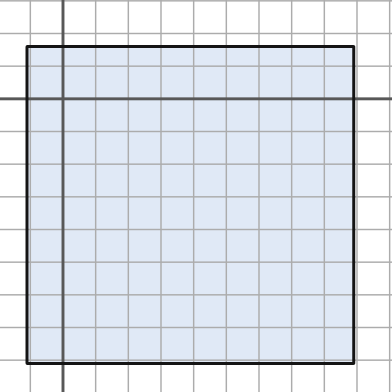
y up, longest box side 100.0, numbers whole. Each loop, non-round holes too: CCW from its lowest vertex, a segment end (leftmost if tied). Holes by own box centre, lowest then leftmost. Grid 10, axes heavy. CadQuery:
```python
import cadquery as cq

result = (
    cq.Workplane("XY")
    .moveTo(-11.0, -81.0)
    .lineTo(89.0, -81.0)
    .lineTo(89.0, 16.0)
    .lineTo(-11.0, 16.0)
    .close()
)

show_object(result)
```